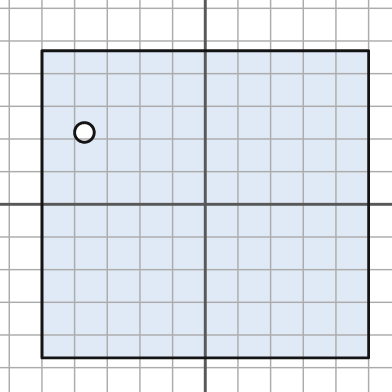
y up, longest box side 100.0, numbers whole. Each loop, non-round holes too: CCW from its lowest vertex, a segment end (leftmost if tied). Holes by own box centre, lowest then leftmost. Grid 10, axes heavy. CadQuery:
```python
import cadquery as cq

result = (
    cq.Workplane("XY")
    .moveTo(-50.0, -47.0)
    .lineTo(50.0, -47.0)
    .lineTo(50.0, 47.0)
    .lineTo(-50.0, 47.0)
    .close()
    .moveTo(-37.0, 22.0)
    .circle(3.0)
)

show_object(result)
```